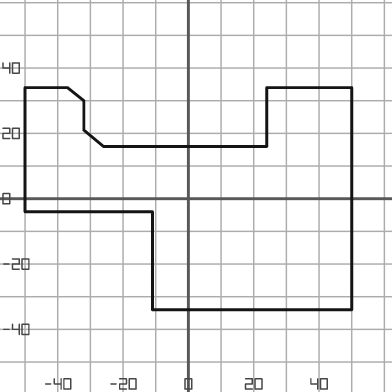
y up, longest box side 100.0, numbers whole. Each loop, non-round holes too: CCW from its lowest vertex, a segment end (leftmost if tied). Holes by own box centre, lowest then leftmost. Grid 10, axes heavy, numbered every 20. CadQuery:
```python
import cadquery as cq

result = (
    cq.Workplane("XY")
    .moveTo(-11.0, -34.0)
    .lineTo(50.0, -34.0)
    .lineTo(50.0, 34.0)
    .lineTo(24.0, 34.0)
    .lineTo(24.0, 16.0)
    .lineTo(-26.0, 16.0)
    .lineTo(-32.0, 21.0)
    .lineTo(-32.0, 30.0)
    .lineTo(-37.0, 34.0)
    .lineTo(-50.0, 34.0)
    .lineTo(-50.0, -4.0)
    .lineTo(-11.0, -4.0)
    .close()
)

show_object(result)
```